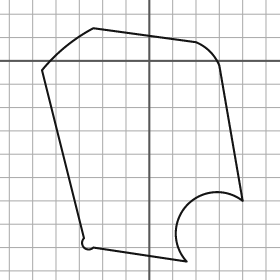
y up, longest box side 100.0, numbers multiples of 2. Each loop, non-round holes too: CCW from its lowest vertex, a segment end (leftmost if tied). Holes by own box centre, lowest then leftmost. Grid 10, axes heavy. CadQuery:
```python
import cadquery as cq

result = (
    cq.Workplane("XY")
    .moveTo(16.0, -86.0)
    .threePointArc((16.0, -62.0), (40.0, -60.0))
    .lineTo(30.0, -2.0)
    .threePointArc((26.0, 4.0), (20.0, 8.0))
    .lineTo(-24.0, 14.0)
    .threePointArc((-36.0, 6.0), (-46.0, -4.0))
    .lineTo(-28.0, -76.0)
    .threePointArc((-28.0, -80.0), (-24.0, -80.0))
    .close()
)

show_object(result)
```